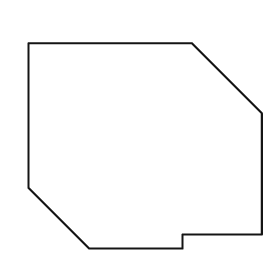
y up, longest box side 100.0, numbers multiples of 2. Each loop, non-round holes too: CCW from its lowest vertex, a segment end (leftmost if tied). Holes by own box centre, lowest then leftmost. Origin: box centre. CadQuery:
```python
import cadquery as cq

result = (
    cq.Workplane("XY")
    .moveTo(-24.0, -44.0)
    .lineTo(16.0, -44.0)
    .lineTo(16.0, -38.0)
    .lineTo(50.0, -38.0)
    .lineTo(50.0, 14.0)
    .lineTo(20.0, 44.0)
    .lineTo(-50.0, 44.0)
    .lineTo(-50.0, -18.0)
    .close()
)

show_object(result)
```